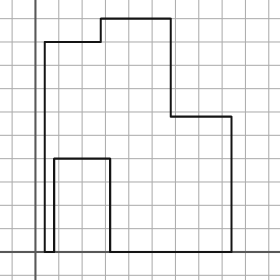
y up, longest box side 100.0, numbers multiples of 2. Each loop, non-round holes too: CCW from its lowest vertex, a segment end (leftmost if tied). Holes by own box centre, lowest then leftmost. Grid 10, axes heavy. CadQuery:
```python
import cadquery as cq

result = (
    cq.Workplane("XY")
    .moveTo(4.0, 0.0)
    .lineTo(8.0, 0.0)
    .lineTo(8.0, 40.0)
    .lineTo(32.0, 40.0)
    .lineTo(32.0, 0.0)
    .lineTo(84.0, 0.0)
    .lineTo(84.0, 58.0)
    .lineTo(58.0, 58.0)
    .lineTo(58.0, 100.0)
    .lineTo(28.0, 100.0)
    .lineTo(28.0, 90.0)
    .lineTo(4.0, 90.0)
    .close()
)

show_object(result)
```